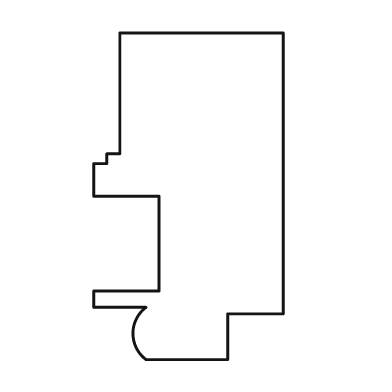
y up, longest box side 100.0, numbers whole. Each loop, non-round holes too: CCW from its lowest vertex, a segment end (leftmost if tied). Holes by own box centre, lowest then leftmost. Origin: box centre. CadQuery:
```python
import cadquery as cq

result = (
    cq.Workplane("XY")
    .moveTo(-13.0, -50.0)
    .lineTo(12.0, -50.0)
    .lineTo(12.0, -36.0)
    .lineTo(29.0, -36.0)
    .lineTo(29.0, 50.0)
    .lineTo(-21.0, 50.0)
    .lineTo(-21.0, 13.0)
    .lineTo(-25.0, 13.0)
    .lineTo(-25.0, 10.0)
    .lineTo(-29.0, 10.0)
    .lineTo(-29.0, 0.0)
    .lineTo(-9.0, 0.0)
    .lineTo(-9.0, -29.0)
    .lineTo(-29.0, -29.0)
    .lineTo(-29.0, -34.0)
    .lineTo(-13.0, -34.0)
    .threePointArc((-17.0, -42.0), (-13.0, -50.0))
    .close()
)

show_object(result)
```